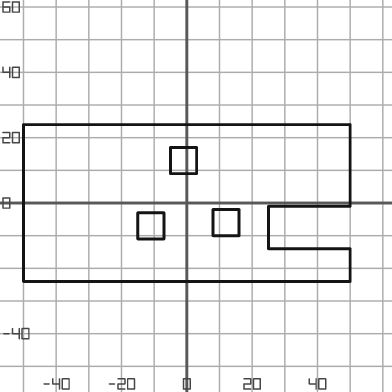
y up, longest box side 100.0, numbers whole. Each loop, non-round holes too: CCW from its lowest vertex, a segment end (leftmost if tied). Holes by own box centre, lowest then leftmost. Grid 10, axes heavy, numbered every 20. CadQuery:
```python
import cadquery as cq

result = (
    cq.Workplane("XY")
    .moveTo(-50.0, -24.0)
    .lineTo(50.0, -24.0)
    .lineTo(50.0, -14.0)
    .lineTo(25.0, -14.0)
    .lineTo(25.0, -1.0)
    .lineTo(50.0, -1.0)
    .lineTo(50.0, 24.0)
    .lineTo(-50.0, 24.0)
    .close()
    .moveTo(-15.0, -11.0)
    .lineTo(-7.0, -11.0)
    .lineTo(-7.0, -3.0)
    .lineTo(-15.0, -3.0)
    .close()
    .moveTo(8.0, -10.0)
    .lineTo(16.0, -10.0)
    .lineTo(16.0, -2.0)
    .lineTo(8.0, -2.0)
    .close()
    .moveTo(-5.0, 9.0)
    .lineTo(3.0, 9.0)
    .lineTo(3.0, 17.0)
    .lineTo(-5.0, 17.0)
    .close()
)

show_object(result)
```